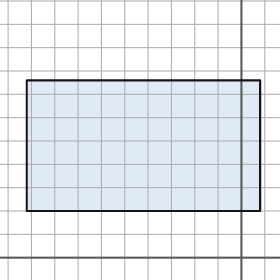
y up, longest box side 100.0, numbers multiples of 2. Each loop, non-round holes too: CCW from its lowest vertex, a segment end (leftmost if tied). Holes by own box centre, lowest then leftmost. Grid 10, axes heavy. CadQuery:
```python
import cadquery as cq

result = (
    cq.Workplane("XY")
    .moveTo(-92.0, 20.0)
    .lineTo(8.0, 20.0)
    .lineTo(8.0, 76.0)
    .lineTo(-92.0, 76.0)
    .close()
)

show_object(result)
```